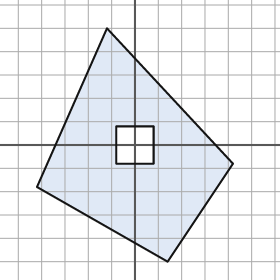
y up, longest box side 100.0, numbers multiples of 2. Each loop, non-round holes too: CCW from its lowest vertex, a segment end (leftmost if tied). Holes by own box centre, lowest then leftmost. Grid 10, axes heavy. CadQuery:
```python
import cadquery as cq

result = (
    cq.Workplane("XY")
    .moveTo(14.0, -50.0)
    .lineTo(42.0, -8.0)
    .lineTo(-12.0, 50.0)
    .lineTo(-42.0, -18.0)
    .close()
    .moveTo(-8.0, -8.0)
    .lineTo(8.0, -8.0)
    .lineTo(8.0, 8.0)
    .lineTo(-8.0, 8.0)
    .close()
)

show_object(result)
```